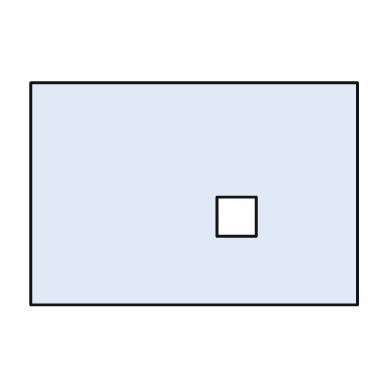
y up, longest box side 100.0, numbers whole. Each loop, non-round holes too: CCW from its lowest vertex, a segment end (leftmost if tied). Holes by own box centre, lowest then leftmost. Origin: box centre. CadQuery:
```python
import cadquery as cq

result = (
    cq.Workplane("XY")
    .moveTo(-50.0, -34.0)
    .lineTo(50.0, -34.0)
    .lineTo(50.0, 34.0)
    .lineTo(-50.0, 34.0)
    .close()
    .moveTo(7.0, -13.0)
    .lineTo(19.0, -13.0)
    .lineTo(19.0, -1.0)
    .lineTo(7.0, -1.0)
    .close()
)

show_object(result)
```